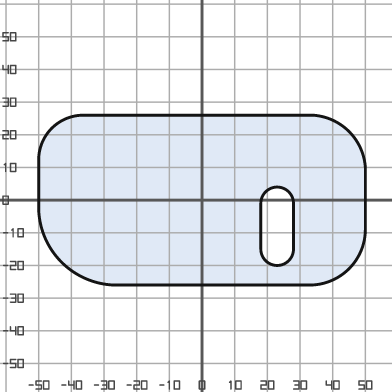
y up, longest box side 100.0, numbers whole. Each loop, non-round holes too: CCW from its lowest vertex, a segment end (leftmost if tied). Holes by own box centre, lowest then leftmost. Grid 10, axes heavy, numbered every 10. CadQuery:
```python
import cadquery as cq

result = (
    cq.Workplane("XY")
    .moveTo(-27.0, -26.0)
    .lineTo(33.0, -26.0)
    .threePointArc((45.0, -21.0), (50.0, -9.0))
    .lineTo(50.0, 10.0)
    .threePointArc((45.0, 21.0), (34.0, 26.0))
    .lineTo(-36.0, 26.0)
    .threePointArc((-46.0, 22.0), (-50.0, 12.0))
    .lineTo(-50.0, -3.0)
    .threePointArc((-43.0, -19.0), (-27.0, -26.0))
    .close()
    .moveTo(18.0, -15.0)
    .threePointArc((23.0, -20.0), (28.0, -15.0))
    .lineTo(28.0, -1.0)
    .threePointArc((23.0, 4.0), (18.0, -1.0))
    .close()
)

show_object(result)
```